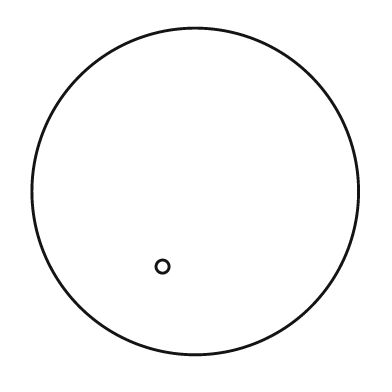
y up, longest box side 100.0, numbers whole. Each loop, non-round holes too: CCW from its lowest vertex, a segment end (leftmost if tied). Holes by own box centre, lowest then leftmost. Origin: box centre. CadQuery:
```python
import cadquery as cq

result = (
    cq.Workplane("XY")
    .moveTo(0.0, 0.0)
    .circle(50.0)
    .moveTo(-10.0, -23.0)
    .circle(2.0)
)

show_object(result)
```